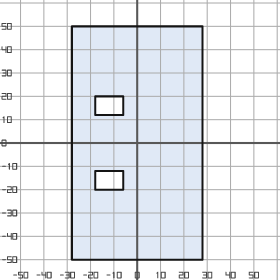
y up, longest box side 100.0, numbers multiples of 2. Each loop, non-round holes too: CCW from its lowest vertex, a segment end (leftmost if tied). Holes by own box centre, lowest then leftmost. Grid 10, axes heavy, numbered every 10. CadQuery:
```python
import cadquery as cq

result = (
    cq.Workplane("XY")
    .moveTo(-28.0, -50.0)
    .lineTo(28.0, -50.0)
    .lineTo(28.0, 50.0)
    .lineTo(-28.0, 50.0)
    .close()
    .moveTo(-18.0, -20.0)
    .lineTo(-6.0, -20.0)
    .lineTo(-6.0, -12.0)
    .lineTo(-18.0, -12.0)
    .close()
    .moveTo(-18.0, 12.0)
    .lineTo(-6.0, 12.0)
    .lineTo(-6.0, 20.0)
    .lineTo(-18.0, 20.0)
    .close()
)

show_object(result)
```